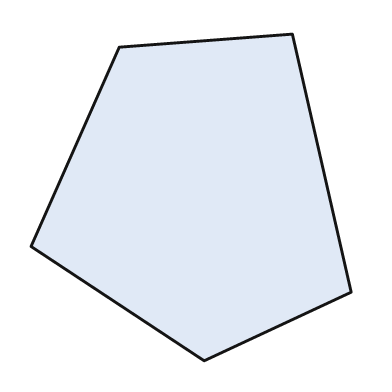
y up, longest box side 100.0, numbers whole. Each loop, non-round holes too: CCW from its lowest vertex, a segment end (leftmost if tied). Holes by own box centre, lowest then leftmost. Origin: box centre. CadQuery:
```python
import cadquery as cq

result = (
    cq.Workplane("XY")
    .moveTo(4.0, -50.0)
    .lineTo(49.0, -29.0)
    .lineTo(31.0, 50.0)
    .lineTo(-22.0, 46.0)
    .lineTo(-49.0, -15.0)
    .close()
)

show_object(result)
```